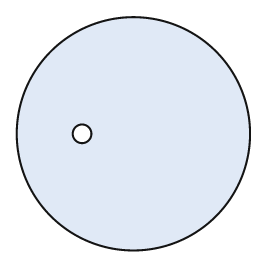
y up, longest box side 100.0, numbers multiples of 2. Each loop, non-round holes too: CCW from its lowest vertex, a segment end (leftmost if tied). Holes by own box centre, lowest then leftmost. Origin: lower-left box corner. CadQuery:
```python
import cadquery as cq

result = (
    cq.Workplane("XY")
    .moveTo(50.0, 50.0)
    .circle(50.0)
    .moveTo(28.0, 50.0)
    .circle(4.0)
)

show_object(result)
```